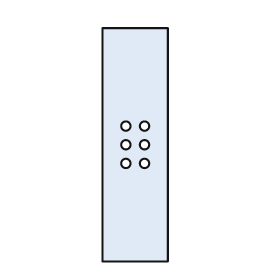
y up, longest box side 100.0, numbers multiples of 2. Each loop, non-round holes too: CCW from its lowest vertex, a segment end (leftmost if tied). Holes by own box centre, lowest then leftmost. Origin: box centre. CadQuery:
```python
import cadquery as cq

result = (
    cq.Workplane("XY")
    .moveTo(-14.0, -50.0)
    .lineTo(14.0, -50.0)
    .lineTo(14.0, 50.0)
    .lineTo(-14.0, 50.0)
    .close()
    .moveTo(-4.0, -8.0)
    .circle(2.0)
    .moveTo(4.0, -8.0)
    .circle(2.0)
    .moveTo(-4.0, 0.0)
    .circle(2.0)
    .moveTo(4.0, 0.0)
    .circle(2.0)
    .moveTo(-4.0, 8.0)
    .circle(2.0)
    .moveTo(4.0, 8.0)
    .circle(2.0)
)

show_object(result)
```